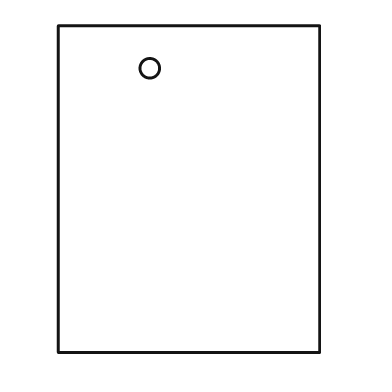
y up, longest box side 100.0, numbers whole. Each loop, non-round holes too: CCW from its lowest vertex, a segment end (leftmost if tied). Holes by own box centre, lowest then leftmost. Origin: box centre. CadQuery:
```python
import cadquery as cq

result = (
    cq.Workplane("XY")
    .moveTo(-40.0, -50.0)
    .lineTo(40.0, -50.0)
    .lineTo(40.0, 50.0)
    .lineTo(-40.0, 50.0)
    .close()
    .moveTo(-12.0, 37.0)
    .circle(3.0)
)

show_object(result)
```